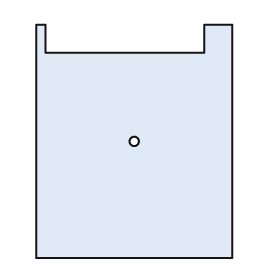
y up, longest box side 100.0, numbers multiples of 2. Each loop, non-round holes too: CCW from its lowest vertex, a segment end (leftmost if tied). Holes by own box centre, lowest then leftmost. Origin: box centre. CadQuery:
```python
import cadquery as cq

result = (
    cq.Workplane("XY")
    .moveTo(-42.0, -50.0)
    .lineTo(42.0, -50.0)
    .lineTo(42.0, 50.0)
    .lineTo(30.0, 50.0)
    .lineTo(30.0, 38.0)
    .lineTo(-38.0, 38.0)
    .lineTo(-38.0, 50.0)
    .lineTo(-42.0, 50.0)
    .close()
    .moveTo(0.0, 0.0)
    .circle(2.0)
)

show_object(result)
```